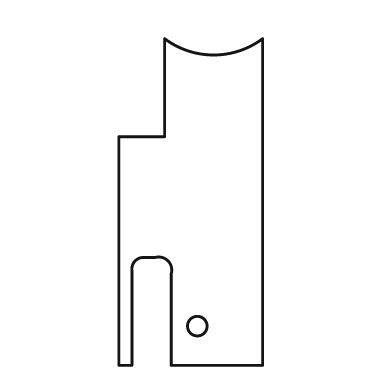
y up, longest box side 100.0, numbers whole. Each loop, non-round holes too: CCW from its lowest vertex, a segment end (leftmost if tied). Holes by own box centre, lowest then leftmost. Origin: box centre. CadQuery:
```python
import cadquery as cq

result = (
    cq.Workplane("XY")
    .moveTo(-22.0, -50.0)
    .lineTo(-18.0, -50.0)
    .lineTo(-18.0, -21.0)
    .threePointArc((-17.0, -18.0), (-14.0, -17.0))
    .lineTo(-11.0, -17.0)
    .threePointArc((-7.0, -18.0), (-6.0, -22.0))
    .lineTo(-6.0, -50.0)
    .lineTo(22.0, -50.0)
    .lineTo(22.0, 50.0)
    .threePointArc((7.0, 45.0), (-8.0, 50.0))
    .lineTo(-8.0, 20.0)
    .lineTo(-22.0, 20.0)
    .close()
    .moveTo(2.0, -38.0)
    .circle(3.0)
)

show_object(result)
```